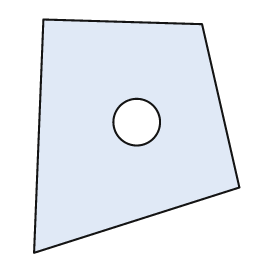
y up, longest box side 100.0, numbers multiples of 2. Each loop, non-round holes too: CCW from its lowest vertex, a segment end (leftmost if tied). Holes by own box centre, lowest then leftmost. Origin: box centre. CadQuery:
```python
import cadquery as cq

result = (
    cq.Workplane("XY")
    .moveTo(-44.0, -50.0)
    .lineTo(44.0, -22.0)
    .lineTo(28.0, 48.0)
    .lineTo(-40.0, 50.0)
    .close()
    .moveTo(0.0, 6.0)
    .circle(10.0)
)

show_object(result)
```